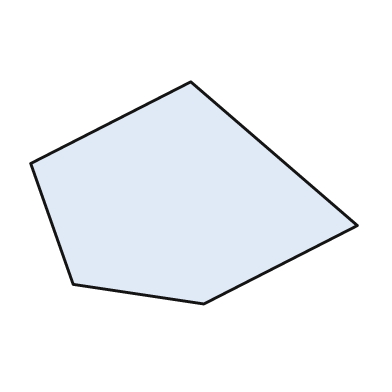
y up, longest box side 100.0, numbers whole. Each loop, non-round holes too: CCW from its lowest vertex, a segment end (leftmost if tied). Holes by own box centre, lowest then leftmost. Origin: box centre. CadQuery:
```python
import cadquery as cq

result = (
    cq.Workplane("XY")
    .moveTo(3.0, -34.0)
    .lineTo(50.0, -10.0)
    .lineTo(-1.0, 34.0)
    .lineTo(-50.0, 9.0)
    .lineTo(-37.0, -28.0)
    .close()
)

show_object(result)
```